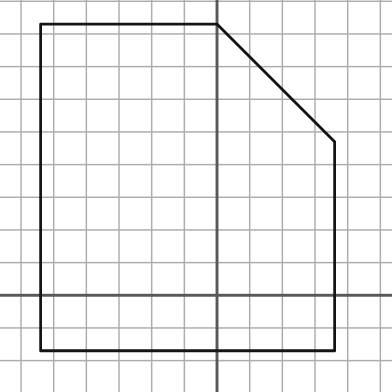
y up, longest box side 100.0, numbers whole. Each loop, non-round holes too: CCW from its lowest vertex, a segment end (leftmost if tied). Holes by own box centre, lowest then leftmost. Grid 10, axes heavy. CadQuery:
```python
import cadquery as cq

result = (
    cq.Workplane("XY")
    .moveTo(-54.0, -17.0)
    .lineTo(36.0, -17.0)
    .lineTo(36.0, 47.0)
    .lineTo(0.0, 83.0)
    .lineTo(-54.0, 83.0)
    .close()
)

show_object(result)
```